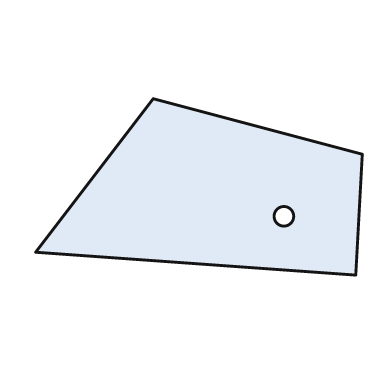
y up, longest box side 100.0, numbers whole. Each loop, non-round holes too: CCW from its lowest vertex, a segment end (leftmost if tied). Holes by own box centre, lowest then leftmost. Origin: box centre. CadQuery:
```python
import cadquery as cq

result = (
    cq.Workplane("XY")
    .moveTo(48.0, -27.0)
    .lineTo(50.0, 10.0)
    .lineTo(-14.0, 27.0)
    .lineTo(-50.0, -20.0)
    .close()
    .moveTo(26.0, -9.0)
    .circle(3.0)
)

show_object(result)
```